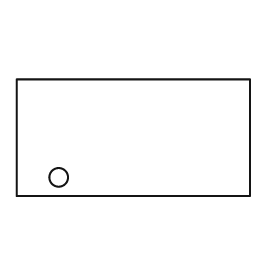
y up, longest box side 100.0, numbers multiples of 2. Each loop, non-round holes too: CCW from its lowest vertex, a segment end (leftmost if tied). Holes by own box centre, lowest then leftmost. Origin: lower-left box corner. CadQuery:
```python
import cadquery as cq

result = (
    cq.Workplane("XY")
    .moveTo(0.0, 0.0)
    .lineTo(100.0, 0.0)
    .lineTo(100.0, 50.0)
    .lineTo(0.0, 50.0)
    .close()
    .moveTo(18.0, 8.0)
    .circle(4.0)
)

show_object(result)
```